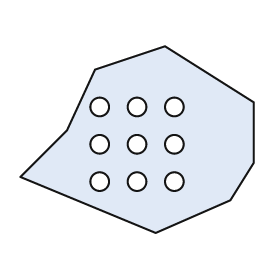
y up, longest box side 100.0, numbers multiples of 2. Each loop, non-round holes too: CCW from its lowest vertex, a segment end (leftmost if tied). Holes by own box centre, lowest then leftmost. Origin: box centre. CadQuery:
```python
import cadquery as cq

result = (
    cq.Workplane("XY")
    .moveTo(8.0, -40.0)
    .lineTo(40.0, -26.0)
    .lineTo(50.0, -10.0)
    .lineTo(50.0, 16.0)
    .lineTo(12.0, 40.0)
    .lineTo(-18.0, 30.0)
    .lineTo(-30.0, 4.0)
    .lineTo(-50.0, -16.0)
    .close()
    .moveTo(-16.0, -18.0)
    .circle(4.0)
    .moveTo(0.0, -18.0)
    .circle(4.0)
    .moveTo(16.0, -18.0)
    .circle(4.0)
    .moveTo(-16.0, -2.0)
    .circle(4.0)
    .moveTo(0.0, -2.0)
    .circle(4.0)
    .moveTo(16.0, -2.0)
    .circle(4.0)
    .moveTo(-16.0, 14.0)
    .circle(4.0)
    .moveTo(0.0, 14.0)
    .circle(4.0)
    .moveTo(16.0, 14.0)
    .circle(4.0)
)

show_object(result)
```